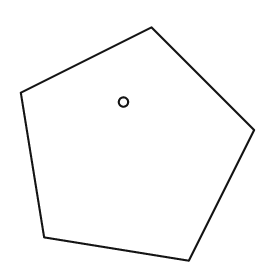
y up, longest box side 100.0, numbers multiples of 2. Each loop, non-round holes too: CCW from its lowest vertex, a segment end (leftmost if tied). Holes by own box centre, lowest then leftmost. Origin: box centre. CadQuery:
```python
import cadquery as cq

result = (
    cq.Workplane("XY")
    .moveTo(22.0, -50.0)
    .lineTo(50.0, 6.0)
    .lineTo(6.0, 50.0)
    .lineTo(-50.0, 22.0)
    .lineTo(-40.0, -40.0)
    .close()
    .moveTo(-6.0, 18.0)
    .circle(2.0)
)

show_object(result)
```